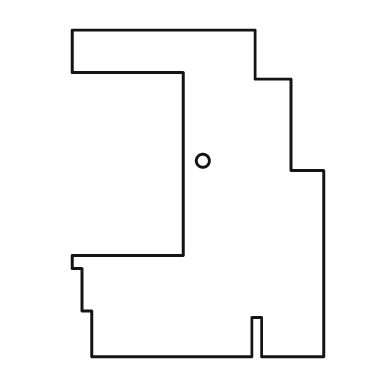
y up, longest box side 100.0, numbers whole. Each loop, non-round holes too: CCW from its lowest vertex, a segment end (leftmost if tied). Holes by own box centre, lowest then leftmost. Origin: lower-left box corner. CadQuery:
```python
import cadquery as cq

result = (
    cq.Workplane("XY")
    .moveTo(6.0, 0.0)
    .lineTo(55.0, 0.0)
    .lineTo(55.0, 12.0)
    .lineTo(58.0, 12.0)
    .lineTo(58.0, 0.0)
    .lineTo(77.0, 0.0)
    .lineTo(77.0, 57.0)
    .lineTo(67.0, 57.0)
    .lineTo(67.0, 85.0)
    .lineTo(56.0, 85.0)
    .lineTo(56.0, 100.0)
    .lineTo(0.0, 100.0)
    .lineTo(0.0, 87.0)
    .lineTo(34.0, 87.0)
    .lineTo(34.0, 31.0)
    .lineTo(0.0, 31.0)
    .lineTo(0.0, 27.0)
    .lineTo(3.0, 27.0)
    .lineTo(3.0, 14.0)
    .lineTo(6.0, 14.0)
    .close()
    .moveTo(40.0, 60.0)
    .circle(2.0)
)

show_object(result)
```